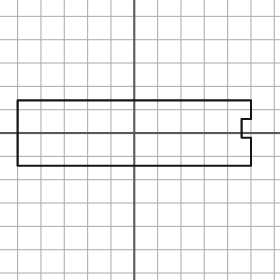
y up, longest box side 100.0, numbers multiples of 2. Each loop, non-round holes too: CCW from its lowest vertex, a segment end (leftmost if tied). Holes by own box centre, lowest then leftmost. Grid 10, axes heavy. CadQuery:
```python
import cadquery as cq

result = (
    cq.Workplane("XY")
    .moveTo(-50.0, -14.0)
    .lineTo(50.0, -14.0)
    .lineTo(50.0, -2.0)
    .lineTo(46.0, -2.0)
    .lineTo(46.0, 6.0)
    .lineTo(50.0, 6.0)
    .lineTo(50.0, 14.0)
    .lineTo(-50.0, 14.0)
    .close()
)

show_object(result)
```